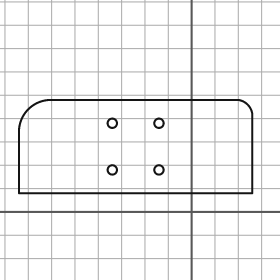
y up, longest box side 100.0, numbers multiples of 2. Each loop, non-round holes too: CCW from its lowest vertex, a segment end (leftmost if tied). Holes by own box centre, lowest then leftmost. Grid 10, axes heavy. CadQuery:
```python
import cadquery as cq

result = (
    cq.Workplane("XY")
    .moveTo(-74.0, 8.0)
    .lineTo(26.0, 8.0)
    .lineTo(26.0, 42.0)
    .threePointArc((24.0, 46.0), (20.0, 48.0))
    .lineTo(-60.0, 48.0)
    .threePointArc((-70.0, 44.0), (-74.0, 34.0))
    .close()
    .moveTo(-34.0, 18.0)
    .circle(2.0)
    .moveTo(-14.0, 18.0)
    .circle(2.0)
    .moveTo(-34.0, 38.0)
    .circle(2.0)
    .moveTo(-14.0, 38.0)
    .circle(2.0)
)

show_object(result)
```